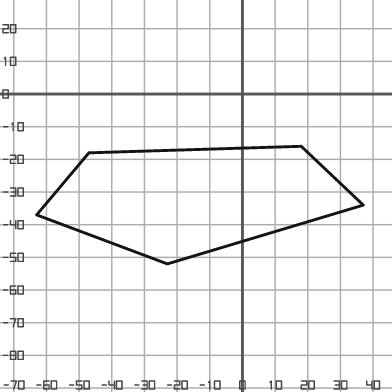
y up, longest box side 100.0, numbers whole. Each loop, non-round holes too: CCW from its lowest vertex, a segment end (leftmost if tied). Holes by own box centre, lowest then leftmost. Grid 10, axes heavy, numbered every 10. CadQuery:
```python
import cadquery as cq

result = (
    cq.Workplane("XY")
    .moveTo(-23.0, -52.0)
    .lineTo(37.0, -34.0)
    .lineTo(18.0, -16.0)
    .lineTo(-47.0, -18.0)
    .lineTo(-63.0, -37.0)
    .close()
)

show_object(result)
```